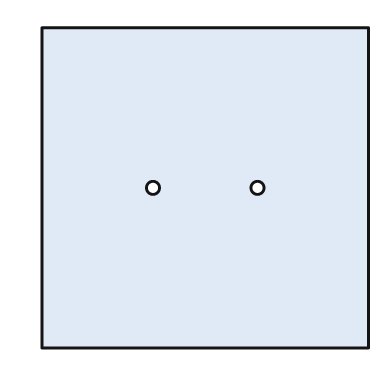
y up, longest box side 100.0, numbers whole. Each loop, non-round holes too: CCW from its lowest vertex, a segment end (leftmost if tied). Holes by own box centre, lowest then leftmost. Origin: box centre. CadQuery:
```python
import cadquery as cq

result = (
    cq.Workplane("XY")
    .moveTo(-50.0, -49.0)
    .lineTo(50.0, -49.0)
    .lineTo(50.0, 49.0)
    .lineTo(-50.0, 49.0)
    .close()
    .moveTo(-16.0, 0.0)
    .circle(2.0)
    .moveTo(16.0, 0.0)
    .circle(2.0)
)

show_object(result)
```